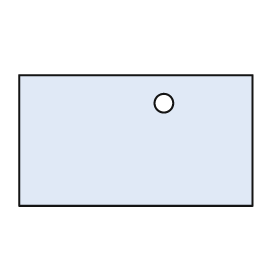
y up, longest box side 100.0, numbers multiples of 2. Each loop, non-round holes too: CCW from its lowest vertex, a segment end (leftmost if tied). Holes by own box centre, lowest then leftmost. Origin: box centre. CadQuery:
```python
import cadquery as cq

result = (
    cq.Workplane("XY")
    .moveTo(-50.0, -28.0)
    .lineTo(50.0, -28.0)
    .lineTo(50.0, 28.0)
    .lineTo(-50.0, 28.0)
    .close()
    .moveTo(12.0, 16.0)
    .circle(4.0)
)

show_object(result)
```